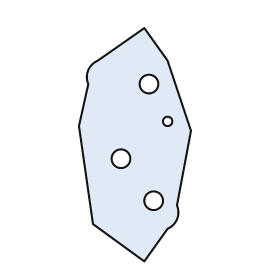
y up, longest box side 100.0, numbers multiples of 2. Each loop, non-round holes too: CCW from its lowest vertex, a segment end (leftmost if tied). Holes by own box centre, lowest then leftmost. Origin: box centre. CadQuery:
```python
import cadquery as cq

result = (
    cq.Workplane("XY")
    .moveTo(4.0, -50.0)
    .lineTo(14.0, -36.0)
    .threePointArc((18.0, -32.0), (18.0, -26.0))
    .lineTo(24.0, 6.0)
    .lineTo(14.0, 36.0)
    .lineTo(4.0, 50.0)
    .lineTo(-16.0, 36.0)
    .threePointArc((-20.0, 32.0), (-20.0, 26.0))
    .lineTo(-24.0, 8.0)
    .lineTo(-18.0, -34.0)
    .close()
    .moveTo(8.0, -24.0)
    .circle(4.0)
    .moveTo(-6.0, -6.0)
    .circle(4.0)
    .moveTo(14.0, 10.0)
    .circle(2.0)
    .moveTo(6.0, 26.0)
    .circle(4.0)
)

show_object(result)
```